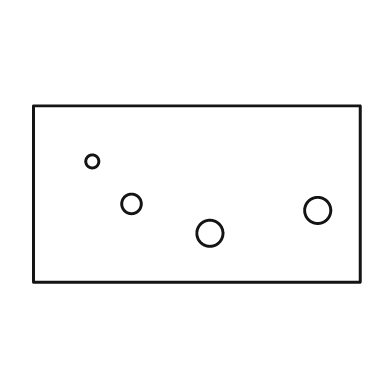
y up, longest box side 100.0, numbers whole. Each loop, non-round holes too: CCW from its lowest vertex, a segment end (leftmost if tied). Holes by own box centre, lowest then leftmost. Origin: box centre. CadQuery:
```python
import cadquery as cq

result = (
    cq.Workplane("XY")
    .moveTo(-50.0, -27.0)
    .lineTo(50.0, -27.0)
    .lineTo(50.0, 27.0)
    .lineTo(-50.0, 27.0)
    .close()
    .moveTo(4.0, -12.0)
    .circle(4.0)
    .moveTo(37.0, -5.0)
    .circle(4.0)
    .moveTo(-20.0, -3.0)
    .circle(3.0)
    .moveTo(-32.0, 10.0)
    .circle(2.0)
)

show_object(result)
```